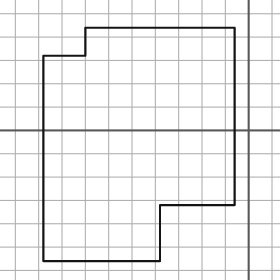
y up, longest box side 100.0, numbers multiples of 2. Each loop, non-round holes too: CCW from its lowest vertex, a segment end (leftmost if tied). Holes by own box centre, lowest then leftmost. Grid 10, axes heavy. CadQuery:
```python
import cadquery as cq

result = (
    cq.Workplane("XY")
    .moveTo(-88.0, -56.0)
    .lineTo(-38.0, -56.0)
    .lineTo(-38.0, -32.0)
    .lineTo(-6.0, -32.0)
    .lineTo(-6.0, 44.0)
    .lineTo(-70.0, 44.0)
    .lineTo(-70.0, 32.0)
    .lineTo(-88.0, 32.0)
    .close()
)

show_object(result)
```